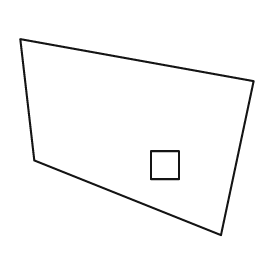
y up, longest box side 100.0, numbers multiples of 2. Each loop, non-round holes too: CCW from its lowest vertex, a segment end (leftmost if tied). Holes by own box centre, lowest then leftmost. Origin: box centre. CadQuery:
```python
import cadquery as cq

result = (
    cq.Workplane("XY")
    .moveTo(36.0, -42.0)
    .lineTo(50.0, 24.0)
    .lineTo(-50.0, 42.0)
    .lineTo(-44.0, -10.0)
    .close()
    .moveTo(6.0, -18.0)
    .lineTo(18.0, -18.0)
    .lineTo(18.0, -6.0)
    .lineTo(6.0, -6.0)
    .close()
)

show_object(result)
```